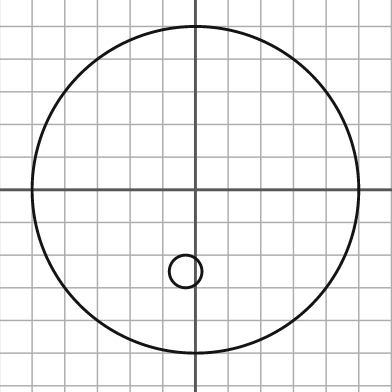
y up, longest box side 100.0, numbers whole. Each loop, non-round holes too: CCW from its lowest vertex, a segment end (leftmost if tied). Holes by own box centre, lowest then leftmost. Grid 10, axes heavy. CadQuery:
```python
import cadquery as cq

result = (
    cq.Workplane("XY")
    .moveTo(0.0, 0.0)
    .circle(50.0)
    .moveTo(-3.0, -25.0)
    .circle(5.0)
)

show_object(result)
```